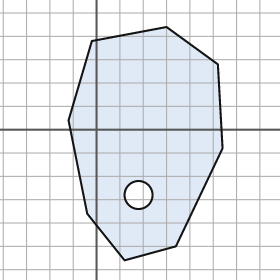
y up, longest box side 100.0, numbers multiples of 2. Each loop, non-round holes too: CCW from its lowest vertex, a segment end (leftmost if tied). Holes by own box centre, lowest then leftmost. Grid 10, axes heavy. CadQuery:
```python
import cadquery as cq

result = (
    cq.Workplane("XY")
    .moveTo(12.0, -56.0)
    .lineTo(34.0, -50.0)
    .lineTo(54.0, -8.0)
    .lineTo(52.0, 28.0)
    .lineTo(30.0, 44.0)
    .lineTo(-2.0, 38.0)
    .lineTo(-12.0, 4.0)
    .lineTo(-4.0, -36.0)
    .close()
    .moveTo(18.0, -28.0)
    .circle(6.0)
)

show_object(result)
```